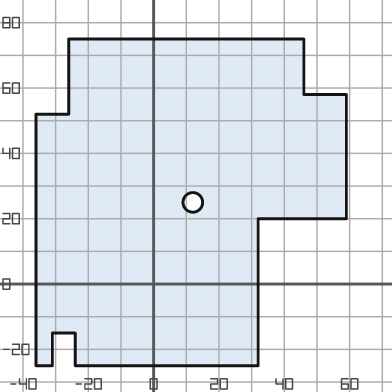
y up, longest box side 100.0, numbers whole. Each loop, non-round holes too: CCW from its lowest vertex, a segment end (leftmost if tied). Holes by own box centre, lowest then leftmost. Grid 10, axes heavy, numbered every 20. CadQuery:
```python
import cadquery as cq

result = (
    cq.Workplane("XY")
    .moveTo(-36.0, -25.0)
    .lineTo(-31.0, -25.0)
    .lineTo(-31.0, -15.0)
    .lineTo(-24.0, -15.0)
    .lineTo(-24.0, -25.0)
    .lineTo(32.0, -25.0)
    .lineTo(32.0, 20.0)
    .lineTo(59.0, 20.0)
    .lineTo(59.0, 58.0)
    .lineTo(46.0, 58.0)
    .lineTo(46.0, 75.0)
    .lineTo(-26.0, 75.0)
    .lineTo(-26.0, 52.0)
    .lineTo(-36.0, 52.0)
    .close()
    .moveTo(12.0, 25.0)
    .circle(3.0)
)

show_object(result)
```